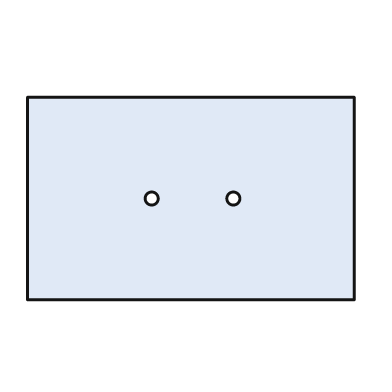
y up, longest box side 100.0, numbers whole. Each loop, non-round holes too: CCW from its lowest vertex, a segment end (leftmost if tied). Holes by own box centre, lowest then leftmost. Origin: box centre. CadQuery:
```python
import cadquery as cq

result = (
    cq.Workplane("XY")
    .moveTo(-50.0, -31.0)
    .lineTo(50.0, -31.0)
    .lineTo(50.0, 31.0)
    .lineTo(-50.0, 31.0)
    .close()
    .moveTo(-12.0, 0.0)
    .circle(2.0)
    .moveTo(13.0, 0.0)
    .circle(2.0)
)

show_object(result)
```